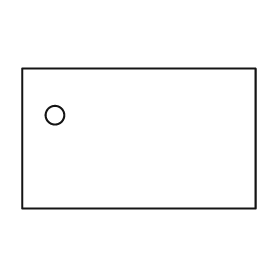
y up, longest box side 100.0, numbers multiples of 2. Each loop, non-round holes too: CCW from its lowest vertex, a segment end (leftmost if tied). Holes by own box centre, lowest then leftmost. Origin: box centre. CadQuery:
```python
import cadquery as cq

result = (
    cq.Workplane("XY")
    .moveTo(-50.0, -30.0)
    .lineTo(50.0, -30.0)
    .lineTo(50.0, 30.0)
    .lineTo(-50.0, 30.0)
    .close()
    .moveTo(-36.0, 10.0)
    .circle(4.0)
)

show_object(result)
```